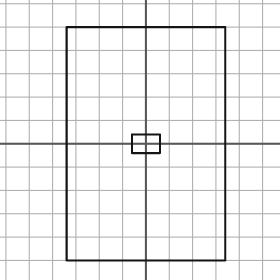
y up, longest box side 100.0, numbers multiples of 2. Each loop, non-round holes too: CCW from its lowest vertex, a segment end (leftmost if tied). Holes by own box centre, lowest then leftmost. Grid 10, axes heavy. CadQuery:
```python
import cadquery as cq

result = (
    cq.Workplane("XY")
    .moveTo(-34.0, -50.0)
    .lineTo(34.0, -50.0)
    .lineTo(34.0, 50.0)
    .lineTo(-34.0, 50.0)
    .close()
    .moveTo(-6.0, -4.0)
    .lineTo(6.0, -4.0)
    .lineTo(6.0, 4.0)
    .lineTo(-6.0, 4.0)
    .close()
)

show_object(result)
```